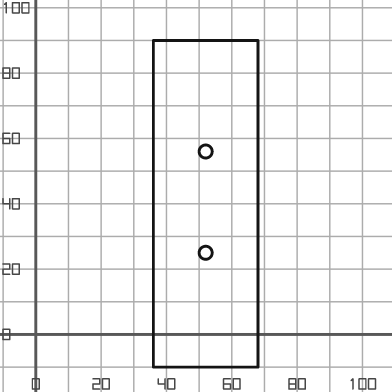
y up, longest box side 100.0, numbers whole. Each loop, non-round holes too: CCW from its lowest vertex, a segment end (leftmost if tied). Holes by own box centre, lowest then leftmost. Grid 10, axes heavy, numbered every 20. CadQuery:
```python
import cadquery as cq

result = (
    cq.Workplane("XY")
    .moveTo(36.0, -10.0)
    .lineTo(68.0, -10.0)
    .lineTo(68.0, 90.0)
    .lineTo(36.0, 90.0)
    .close()
    .moveTo(52.0, 25.0)
    .circle(2.0)
    .moveTo(52.0, 56.0)
    .circle(2.0)
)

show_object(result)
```